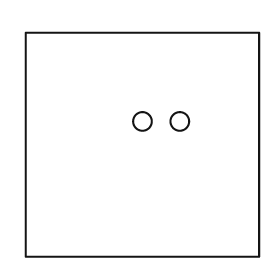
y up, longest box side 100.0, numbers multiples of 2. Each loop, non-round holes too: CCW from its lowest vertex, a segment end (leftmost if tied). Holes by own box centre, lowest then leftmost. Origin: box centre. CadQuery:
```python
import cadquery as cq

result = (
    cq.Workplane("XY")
    .moveTo(-50.0, -48.0)
    .lineTo(50.0, -48.0)
    .lineTo(50.0, 48.0)
    .lineTo(-50.0, 48.0)
    .close()
    .moveTo(0.0, 10.0)
    .circle(4.0)
    .moveTo(16.0, 10.0)
    .circle(4.0)
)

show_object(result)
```